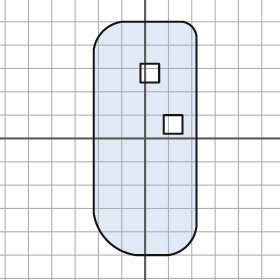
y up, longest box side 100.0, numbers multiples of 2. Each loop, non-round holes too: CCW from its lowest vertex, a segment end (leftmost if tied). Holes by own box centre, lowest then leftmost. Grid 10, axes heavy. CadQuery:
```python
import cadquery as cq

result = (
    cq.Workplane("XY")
    .moveTo(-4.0, -50.0)
    .lineTo(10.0, -50.0)
    .threePointArc((18.0, -46.0), (22.0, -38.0))
    .lineTo(22.0, 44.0)
    .threePointArc((20.0, 48.0), (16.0, 50.0))
    .lineTo(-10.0, 50.0)
    .threePointArc((-18.0, 46.0), (-22.0, 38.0))
    .lineTo(-22.0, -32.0)
    .threePointArc((-16.0, -44.0), (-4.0, -50.0))
    .close()
    .moveTo(8.0, 2.0)
    .lineTo(16.0, 2.0)
    .lineTo(16.0, 10.0)
    .lineTo(8.0, 10.0)
    .close()
    .moveTo(-2.0, 24.0)
    .lineTo(6.0, 24.0)
    .lineTo(6.0, 32.0)
    .lineTo(-2.0, 32.0)
    .close()
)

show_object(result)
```